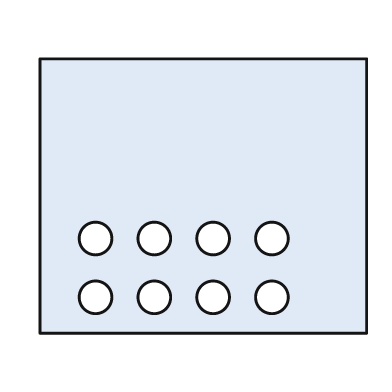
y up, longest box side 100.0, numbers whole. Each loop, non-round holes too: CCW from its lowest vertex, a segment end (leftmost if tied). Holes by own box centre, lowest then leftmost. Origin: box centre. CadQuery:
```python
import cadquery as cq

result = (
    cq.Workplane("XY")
    .moveTo(-50.0, -42.0)
    .lineTo(50.0, -42.0)
    .lineTo(50.0, 42.0)
    .lineTo(-50.0, 42.0)
    .close()
    .moveTo(-33.0, -31.0)
    .circle(5.0)
    .moveTo(-15.0, -31.0)
    .circle(5.0)
    .moveTo(3.0, -31.0)
    .circle(5.0)
    .moveTo(21.0, -31.0)
    .circle(5.0)
    .moveTo(-33.0, -13.0)
    .circle(5.0)
    .moveTo(-15.0, -13.0)
    .circle(5.0)
    .moveTo(3.0, -13.0)
    .circle(5.0)
    .moveTo(21.0, -13.0)
    .circle(5.0)
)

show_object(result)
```